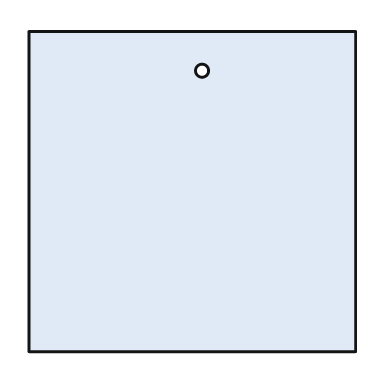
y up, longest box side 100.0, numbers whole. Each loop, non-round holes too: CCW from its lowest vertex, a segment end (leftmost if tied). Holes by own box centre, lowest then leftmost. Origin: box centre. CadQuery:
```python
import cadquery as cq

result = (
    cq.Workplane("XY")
    .moveTo(-50.0, -49.0)
    .lineTo(50.0, -49.0)
    .lineTo(50.0, 49.0)
    .lineTo(-50.0, 49.0)
    .close()
    .moveTo(3.0, 37.0)
    .circle(2.0)
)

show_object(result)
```